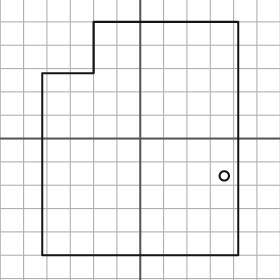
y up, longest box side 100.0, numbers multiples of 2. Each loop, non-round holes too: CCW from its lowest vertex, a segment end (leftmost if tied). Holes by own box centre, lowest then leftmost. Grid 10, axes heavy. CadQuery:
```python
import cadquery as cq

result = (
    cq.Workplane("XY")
    .moveTo(-42.0, -50.0)
    .lineTo(42.0, -50.0)
    .lineTo(42.0, 50.0)
    .lineTo(-20.0, 50.0)
    .lineTo(-20.0, 28.0)
    .lineTo(-42.0, 28.0)
    .close()
    .moveTo(36.0, -16.0)
    .circle(2.0)
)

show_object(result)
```